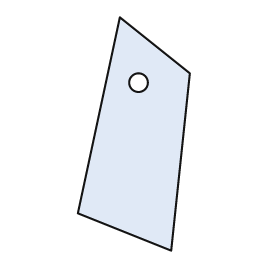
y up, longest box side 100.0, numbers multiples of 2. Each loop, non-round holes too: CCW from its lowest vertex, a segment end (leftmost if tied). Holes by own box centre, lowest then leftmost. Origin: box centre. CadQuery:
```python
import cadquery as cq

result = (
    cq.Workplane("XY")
    .moveTo(16.0, -50.0)
    .lineTo(24.0, 26.0)
    .lineTo(-6.0, 50.0)
    .lineTo(-24.0, -34.0)
    .close()
    .moveTo(2.0, 22.0)
    .circle(4.0)
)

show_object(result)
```